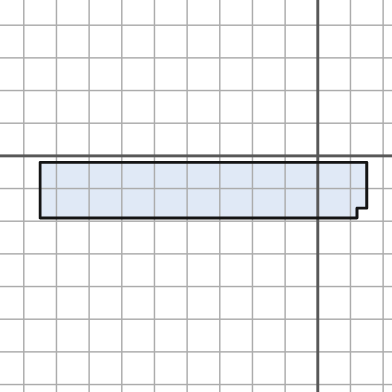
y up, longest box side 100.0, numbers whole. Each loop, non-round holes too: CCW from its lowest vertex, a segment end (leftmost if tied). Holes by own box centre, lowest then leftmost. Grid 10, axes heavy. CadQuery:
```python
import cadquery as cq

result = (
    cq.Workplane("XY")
    .moveTo(-85.0, -19.0)
    .lineTo(12.0, -19.0)
    .lineTo(12.0, -16.0)
    .lineTo(15.0, -16.0)
    .lineTo(15.0, -2.0)
    .lineTo(-85.0, -2.0)
    .close()
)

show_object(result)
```